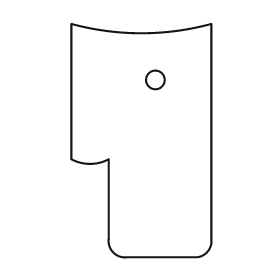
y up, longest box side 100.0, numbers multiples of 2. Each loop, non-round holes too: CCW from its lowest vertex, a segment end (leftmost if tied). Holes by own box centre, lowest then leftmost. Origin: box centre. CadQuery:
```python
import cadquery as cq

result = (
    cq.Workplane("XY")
    .moveTo(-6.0, -50.0)
    .lineTo(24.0, -50.0)
    .threePointArc((28.0, -48.0), (30.0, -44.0))
    .lineTo(30.0, 50.0)
    .threePointArc((0.0, 46.0), (-30.0, 50.0))
    .lineTo(-30.0, -8.0)
    .threePointArc((-22.0, -10.0), (-14.0, -8.0))
    .lineTo(-14.0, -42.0)
    .threePointArc((-12.0, -48.0), (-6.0, -50.0))
    .close()
    .moveTo(6.0, 26.0)
    .circle(4.0)
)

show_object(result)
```